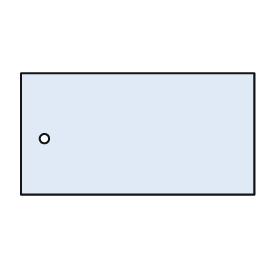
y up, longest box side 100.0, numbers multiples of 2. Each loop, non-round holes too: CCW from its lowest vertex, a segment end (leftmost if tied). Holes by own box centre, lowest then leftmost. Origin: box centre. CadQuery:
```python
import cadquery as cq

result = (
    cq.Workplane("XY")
    .moveTo(-50.0, -26.0)
    .lineTo(50.0, -26.0)
    .lineTo(50.0, 26.0)
    .lineTo(-50.0, 26.0)
    .close()
    .moveTo(-40.0, -2.0)
    .circle(2.0)
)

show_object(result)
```